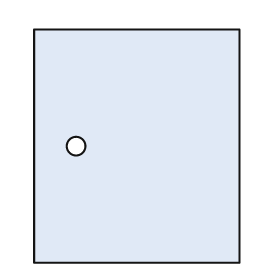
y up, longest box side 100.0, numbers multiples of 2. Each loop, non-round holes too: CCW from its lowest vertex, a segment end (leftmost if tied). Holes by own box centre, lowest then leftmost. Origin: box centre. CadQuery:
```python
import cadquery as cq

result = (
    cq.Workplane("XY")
    .moveTo(-44.0, -50.0)
    .lineTo(44.0, -50.0)
    .lineTo(44.0, 50.0)
    .lineTo(-44.0, 50.0)
    .close()
    .moveTo(-26.0, 0.0)
    .circle(4.0)
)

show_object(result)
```